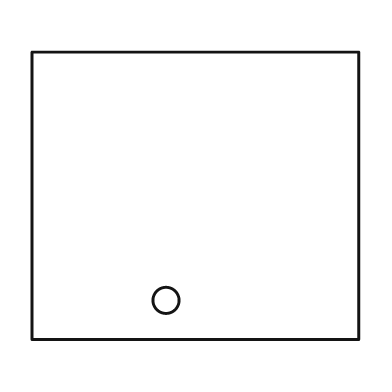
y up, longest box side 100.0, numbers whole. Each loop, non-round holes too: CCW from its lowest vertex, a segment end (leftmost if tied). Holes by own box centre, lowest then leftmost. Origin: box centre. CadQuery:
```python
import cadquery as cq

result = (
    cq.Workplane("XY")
    .moveTo(-50.0, -44.0)
    .lineTo(50.0, -44.0)
    .lineTo(50.0, 44.0)
    .lineTo(-50.0, 44.0)
    .close()
    .moveTo(-9.0, -32.0)
    .circle(4.0)
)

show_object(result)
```